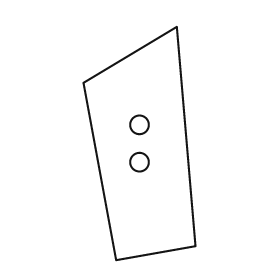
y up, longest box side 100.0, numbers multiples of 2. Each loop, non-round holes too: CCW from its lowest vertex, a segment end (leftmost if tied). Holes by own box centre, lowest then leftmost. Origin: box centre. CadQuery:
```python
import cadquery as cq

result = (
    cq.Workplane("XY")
    .moveTo(-10.0, -50.0)
    .lineTo(24.0, -44.0)
    .lineTo(16.0, 50.0)
    .lineTo(-24.0, 26.0)
    .close()
    .moveTo(0.0, -8.0)
    .circle(4.0)
    .moveTo(0.0, 8.0)
    .circle(4.0)
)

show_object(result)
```